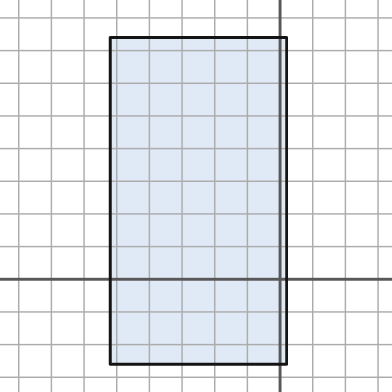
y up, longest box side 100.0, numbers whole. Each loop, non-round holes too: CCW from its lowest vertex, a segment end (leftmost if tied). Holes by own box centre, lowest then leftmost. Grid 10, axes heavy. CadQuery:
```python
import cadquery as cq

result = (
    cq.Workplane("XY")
    .moveTo(-52.0, -26.0)
    .lineTo(2.0, -26.0)
    .lineTo(2.0, 74.0)
    .lineTo(-52.0, 74.0)
    .close()
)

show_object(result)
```